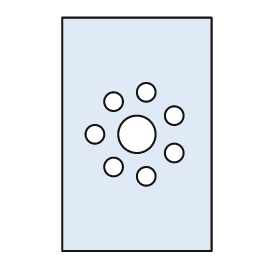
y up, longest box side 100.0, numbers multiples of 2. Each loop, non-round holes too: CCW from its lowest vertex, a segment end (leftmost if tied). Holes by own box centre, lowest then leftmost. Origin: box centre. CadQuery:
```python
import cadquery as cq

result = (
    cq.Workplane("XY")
    .moveTo(-32.0, -50.0)
    .lineTo(32.0, -50.0)
    .lineTo(32.0, 50.0)
    .lineTo(-32.0, 50.0)
    .close()
    .moveTo(4.0, -18.0)
    .circle(4.0)
    .moveTo(-10.0, -14.0)
    .circle(4.0)
    .moveTo(16.0, -8.0)
    .circle(4.0)
    .moveTo(-18.0, 0.0)
    .circle(4.0)
    .moveTo(0.0, 0.0)
    .circle(8.0)
    .moveTo(16.0, 8.0)
    .circle(4.0)
    .moveTo(-10.0, 14.0)
    .circle(4.0)
    .moveTo(4.0, 18.0)
    .circle(4.0)
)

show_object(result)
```